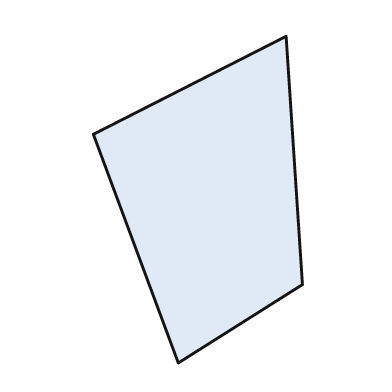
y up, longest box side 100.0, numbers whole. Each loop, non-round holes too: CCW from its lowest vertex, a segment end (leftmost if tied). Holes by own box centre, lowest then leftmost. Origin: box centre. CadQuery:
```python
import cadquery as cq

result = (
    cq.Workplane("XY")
    .moveTo(-6.0, -50.0)
    .lineTo(32.0, -26.0)
    .lineTo(27.0, 50.0)
    .lineTo(-32.0, 20.0)
    .close()
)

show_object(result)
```